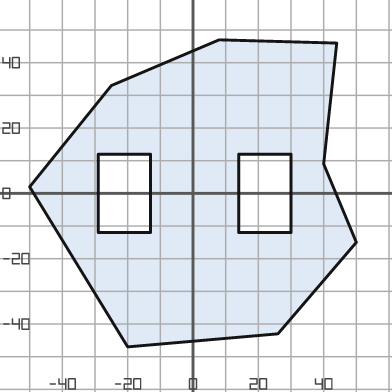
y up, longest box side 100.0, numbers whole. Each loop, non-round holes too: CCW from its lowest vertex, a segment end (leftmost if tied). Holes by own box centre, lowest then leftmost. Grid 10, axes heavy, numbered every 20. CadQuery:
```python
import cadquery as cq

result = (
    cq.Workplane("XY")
    .moveTo(-20.0, -47.0)
    .lineTo(26.0, -43.0)
    .lineTo(50.0, -15.0)
    .lineTo(40.0, 9.0)
    .lineTo(44.0, 46.0)
    .lineTo(8.0, 47.0)
    .lineTo(-25.0, 33.0)
    .lineTo(-50.0, 2.0)
    .close()
    .moveTo(-29.0, -12.0)
    .lineTo(-13.0, -12.0)
    .lineTo(-13.0, 12.0)
    .lineTo(-29.0, 12.0)
    .close()
    .moveTo(14.0, -12.0)
    .lineTo(30.0, -12.0)
    .lineTo(30.0, 12.0)
    .lineTo(14.0, 12.0)
    .close()
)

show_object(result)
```